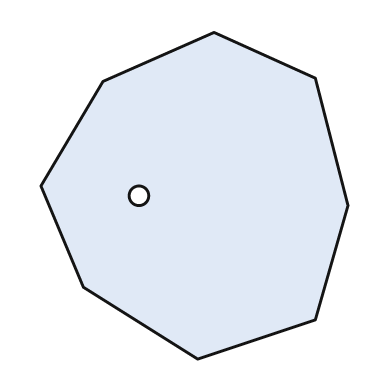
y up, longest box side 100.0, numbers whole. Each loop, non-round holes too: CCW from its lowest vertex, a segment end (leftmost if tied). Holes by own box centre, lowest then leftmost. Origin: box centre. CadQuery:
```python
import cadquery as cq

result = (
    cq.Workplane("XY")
    .moveTo(1.0, -50.0)
    .lineTo(37.0, -38.0)
    .lineTo(47.0, -3.0)
    .lineTo(37.0, 36.0)
    .lineTo(6.0, 50.0)
    .lineTo(-28.0, 35.0)
    .lineTo(-47.0, 3.0)
    .lineTo(-34.0, -28.0)
    .close()
    .moveTo(-17.0, 0.0)
    .circle(3.0)
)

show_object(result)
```